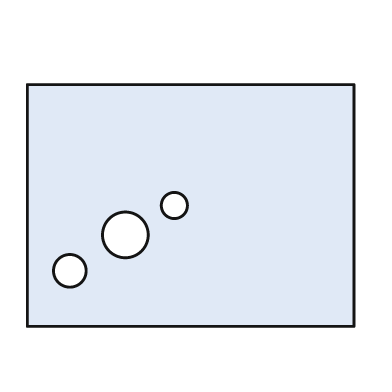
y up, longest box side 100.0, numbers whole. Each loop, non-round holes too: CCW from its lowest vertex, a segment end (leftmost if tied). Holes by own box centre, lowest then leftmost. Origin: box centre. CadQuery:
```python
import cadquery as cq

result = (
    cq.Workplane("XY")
    .moveTo(-50.0, -37.0)
    .lineTo(50.0, -37.0)
    .lineTo(50.0, 37.0)
    .lineTo(-50.0, 37.0)
    .close()
    .moveTo(-37.0, -20.0)
    .circle(5.0)
    .moveTo(-20.0, -9.0)
    .circle(7.0)
    .moveTo(-5.0, 0.0)
    .circle(4.0)
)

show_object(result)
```